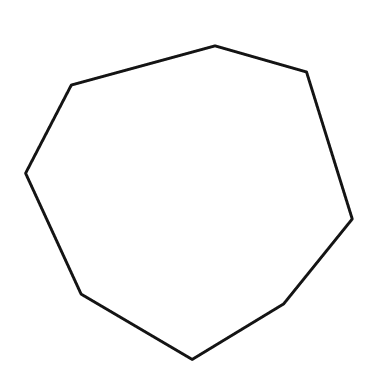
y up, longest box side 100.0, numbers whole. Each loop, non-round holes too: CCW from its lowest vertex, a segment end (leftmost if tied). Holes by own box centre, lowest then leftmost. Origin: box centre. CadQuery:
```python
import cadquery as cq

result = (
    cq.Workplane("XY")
    .moveTo(1.0, -48.0)
    .lineTo(29.0, -31.0)
    .lineTo(50.0, -5.0)
    .lineTo(36.0, 40.0)
    .lineTo(8.0, 48.0)
    .lineTo(-36.0, 36.0)
    .lineTo(-50.0, 9.0)
    .lineTo(-33.0, -28.0)
    .close()
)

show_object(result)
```